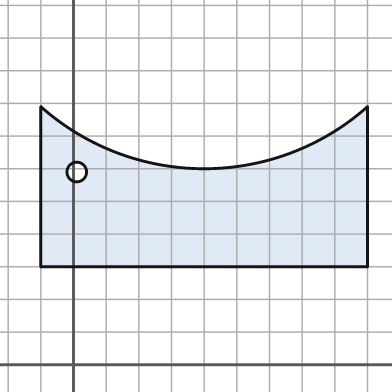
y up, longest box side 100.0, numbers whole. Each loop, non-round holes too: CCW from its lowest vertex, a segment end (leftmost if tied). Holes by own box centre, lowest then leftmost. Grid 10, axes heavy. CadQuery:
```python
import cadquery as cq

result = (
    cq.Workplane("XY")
    .moveTo(-10.0, 30.0)
    .lineTo(90.0, 30.0)
    .lineTo(90.0, 79.0)
    .threePointArc((40.0, 60.0), (-10.0, 79.0))
    .close()
    .moveTo(1.0, 59.0)
    .circle(3.0)
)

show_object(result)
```